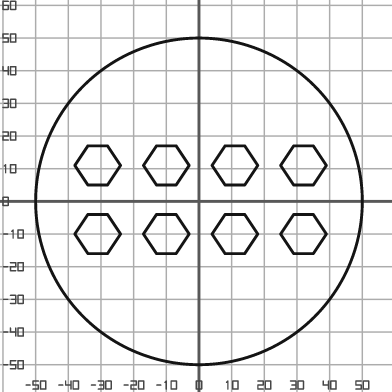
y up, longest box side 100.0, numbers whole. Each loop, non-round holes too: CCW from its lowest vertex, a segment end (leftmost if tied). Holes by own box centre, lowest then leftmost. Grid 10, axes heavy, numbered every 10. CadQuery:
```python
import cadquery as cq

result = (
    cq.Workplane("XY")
    .moveTo(0.0, 0.0)
    .circle(50.0)
    .moveTo(-34.0, -16.0)
    .lineTo(-28.0, -16.0)
    .lineTo(-24.0, -10.0)
    .lineTo(-28.0, -4.0)
    .lineTo(-34.0, -4.0)
    .lineTo(-38.0, -10.0)
    .close()
    .moveTo(-13.0, -16.0)
    .lineTo(-7.0, -16.0)
    .lineTo(-3.0, -10.0)
    .lineTo(-7.0, -4.0)
    .lineTo(-13.0, -4.0)
    .lineTo(-17.0, -10.0)
    .close()
    .moveTo(8.0, -16.0)
    .lineTo(14.0, -16.0)
    .lineTo(18.0, -10.0)
    .lineTo(14.0, -4.0)
    .lineTo(8.0, -4.0)
    .lineTo(4.0, -10.0)
    .close()
    .moveTo(29.0, -16.0)
    .lineTo(35.0, -16.0)
    .lineTo(39.0, -10.0)
    .lineTo(35.0, -4.0)
    .lineTo(29.0, -4.0)
    .lineTo(25.0, -10.0)
    .close()
    .moveTo(-34.0, 5.0)
    .lineTo(-28.0, 5.0)
    .lineTo(-24.0, 11.0)
    .lineTo(-28.0, 17.0)
    .lineTo(-34.0, 17.0)
    .lineTo(-38.0, 11.0)
    .close()
    .moveTo(-13.0, 5.0)
    .lineTo(-7.0, 5.0)
    .lineTo(-3.0, 11.0)
    .lineTo(-7.0, 17.0)
    .lineTo(-13.0, 17.0)
    .lineTo(-17.0, 11.0)
    .close()
    .moveTo(8.0, 5.0)
    .lineTo(14.0, 5.0)
    .lineTo(18.0, 11.0)
    .lineTo(14.0, 17.0)
    .lineTo(8.0, 17.0)
    .lineTo(4.0, 11.0)
    .close()
    .moveTo(29.0, 5.0)
    .lineTo(35.0, 5.0)
    .lineTo(39.0, 11.0)
    .lineTo(35.0, 17.0)
    .lineTo(29.0, 17.0)
    .lineTo(25.0, 11.0)
    .close()
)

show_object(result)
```